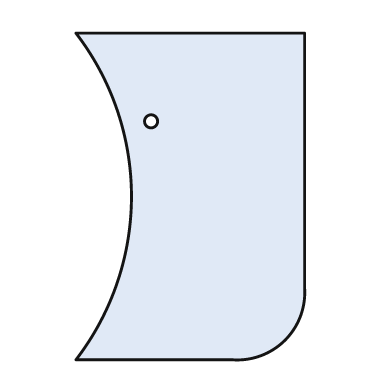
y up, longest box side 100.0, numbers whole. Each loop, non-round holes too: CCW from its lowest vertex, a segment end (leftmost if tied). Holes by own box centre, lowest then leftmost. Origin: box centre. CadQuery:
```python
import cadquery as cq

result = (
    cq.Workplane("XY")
    .moveTo(-35.0, -50.0)
    .lineTo(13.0, -50.0)
    .threePointArc((29.0, -44.0), (35.0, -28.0))
    .lineTo(35.0, 50.0)
    .lineTo(-35.0, 50.0)
    .threePointArc((-18.0, 0.0), (-35.0, -50.0))
    .close()
    .moveTo(-12.0, 23.0)
    .circle(2.0)
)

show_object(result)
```